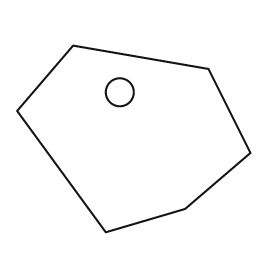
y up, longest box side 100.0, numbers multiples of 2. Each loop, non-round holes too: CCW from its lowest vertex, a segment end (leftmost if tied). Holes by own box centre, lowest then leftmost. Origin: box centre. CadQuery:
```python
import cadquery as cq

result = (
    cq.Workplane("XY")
    .moveTo(-12.0, -40.0)
    .lineTo(22.0, -30.0)
    .lineTo(50.0, -6.0)
    .lineTo(32.0, 30.0)
    .lineTo(-26.0, 40.0)
    .lineTo(-50.0, 12.0)
    .close()
    .moveTo(-6.0, 20.0)
    .circle(6.0)
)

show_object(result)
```